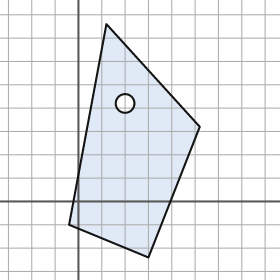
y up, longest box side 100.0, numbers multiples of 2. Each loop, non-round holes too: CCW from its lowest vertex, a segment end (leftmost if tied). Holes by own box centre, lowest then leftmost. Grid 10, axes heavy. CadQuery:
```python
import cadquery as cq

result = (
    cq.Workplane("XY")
    .moveTo(30.0, -24.0)
    .lineTo(52.0, 32.0)
    .lineTo(12.0, 76.0)
    .lineTo(-4.0, -10.0)
    .close()
    .moveTo(20.0, 42.0)
    .circle(4.0)
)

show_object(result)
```